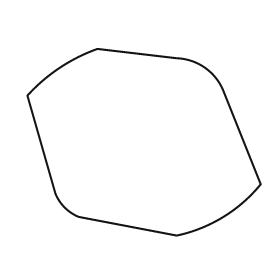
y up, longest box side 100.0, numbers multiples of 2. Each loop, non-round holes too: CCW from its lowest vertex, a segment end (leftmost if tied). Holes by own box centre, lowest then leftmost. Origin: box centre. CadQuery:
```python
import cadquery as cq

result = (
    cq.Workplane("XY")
    .moveTo(14.0, -40.0)
    .threePointArc((34.0, -32.0), (50.0, -18.0))
    .lineTo(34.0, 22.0)
    .threePointArc((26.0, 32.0), (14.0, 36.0))
    .lineTo(-20.0, 40.0)
    .threePointArc((-36.0, 32.0), (-50.0, 20.0))
    .lineTo(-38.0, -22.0)
    .threePointArc((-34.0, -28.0), (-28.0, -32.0))
    .close()
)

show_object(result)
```